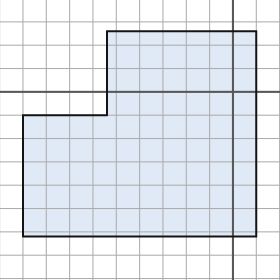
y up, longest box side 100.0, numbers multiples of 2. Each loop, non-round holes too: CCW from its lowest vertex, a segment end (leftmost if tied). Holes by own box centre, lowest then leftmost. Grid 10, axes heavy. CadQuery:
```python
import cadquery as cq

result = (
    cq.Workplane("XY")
    .moveTo(-90.0, -62.0)
    .lineTo(10.0, -62.0)
    .lineTo(10.0, 26.0)
    .lineTo(-54.0, 26.0)
    .lineTo(-54.0, -10.0)
    .lineTo(-90.0, -10.0)
    .close()
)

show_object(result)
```